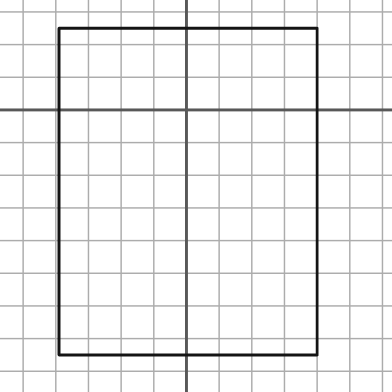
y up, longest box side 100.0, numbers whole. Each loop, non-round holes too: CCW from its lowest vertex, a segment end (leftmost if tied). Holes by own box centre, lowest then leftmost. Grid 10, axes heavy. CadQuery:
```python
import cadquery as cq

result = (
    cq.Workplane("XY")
    .moveTo(-39.0, -75.0)
    .lineTo(40.0, -75.0)
    .lineTo(40.0, 25.0)
    .lineTo(-39.0, 25.0)
    .close()
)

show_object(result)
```